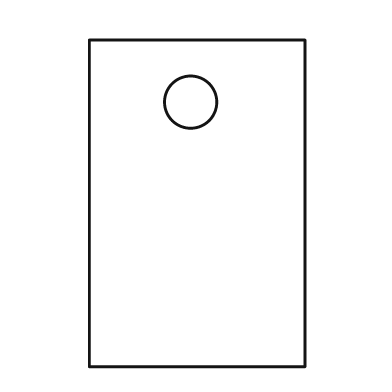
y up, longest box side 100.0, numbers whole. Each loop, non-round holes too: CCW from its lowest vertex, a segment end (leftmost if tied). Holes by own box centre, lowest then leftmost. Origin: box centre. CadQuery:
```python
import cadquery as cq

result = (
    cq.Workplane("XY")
    .moveTo(-33.0, -50.0)
    .lineTo(33.0, -50.0)
    .lineTo(33.0, 50.0)
    .lineTo(-33.0, 50.0)
    .close()
    .moveTo(-2.0, 31.0)
    .circle(8.0)
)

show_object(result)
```